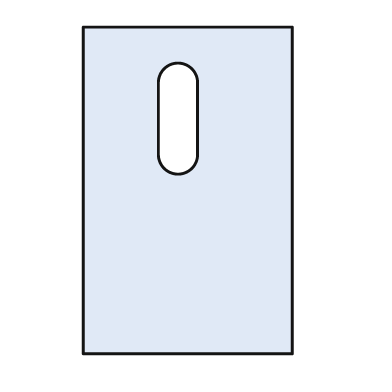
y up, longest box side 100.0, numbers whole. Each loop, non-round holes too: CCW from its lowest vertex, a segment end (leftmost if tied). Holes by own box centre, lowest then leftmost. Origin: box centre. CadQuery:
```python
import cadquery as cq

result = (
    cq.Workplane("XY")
    .moveTo(-32.0, -50.0)
    .lineTo(32.0, -50.0)
    .lineTo(32.0, 50.0)
    .lineTo(-32.0, 50.0)
    .close()
    .moveTo(-9.0, 11.0)
    .threePointArc((-3.0, 5.0), (3.0, 11.0))
    .lineTo(3.0, 33.0)
    .threePointArc((-3.0, 39.0), (-9.0, 33.0))
    .close()
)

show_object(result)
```